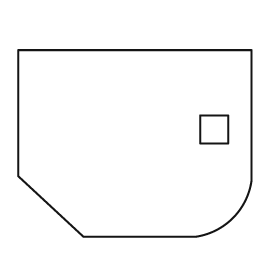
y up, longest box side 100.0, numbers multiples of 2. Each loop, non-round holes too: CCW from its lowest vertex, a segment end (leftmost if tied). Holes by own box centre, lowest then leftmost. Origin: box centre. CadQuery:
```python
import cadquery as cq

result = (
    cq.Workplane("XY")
    .moveTo(-22.0, -40.0)
    .lineTo(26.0, -40.0)
    .threePointArc((42.0, -32.0), (50.0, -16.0))
    .lineTo(50.0, 40.0)
    .lineTo(-50.0, 40.0)
    .lineTo(-50.0, -14.0)
    .close()
    .moveTo(28.0, 0.0)
    .lineTo(40.0, 0.0)
    .lineTo(40.0, 12.0)
    .lineTo(28.0, 12.0)
    .close()
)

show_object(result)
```